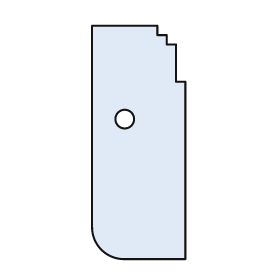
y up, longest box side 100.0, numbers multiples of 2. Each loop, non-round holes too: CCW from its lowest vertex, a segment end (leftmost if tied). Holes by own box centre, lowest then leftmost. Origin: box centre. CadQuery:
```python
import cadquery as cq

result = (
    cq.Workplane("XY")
    .moveTo(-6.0, -50.0)
    .lineTo(20.0, -50.0)
    .lineTo(20.0, 26.0)
    .lineTo(16.0, 26.0)
    .lineTo(16.0, 42.0)
    .lineTo(12.0, 42.0)
    .lineTo(12.0, 46.0)
    .lineTo(8.0, 46.0)
    .lineTo(8.0, 50.0)
    .lineTo(-20.0, 50.0)
    .lineTo(-20.0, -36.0)
    .threePointArc((-16.0, -46.0), (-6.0, -50.0))
    .close()
    .moveTo(-6.0, 10.0)
    .circle(4.0)
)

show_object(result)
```